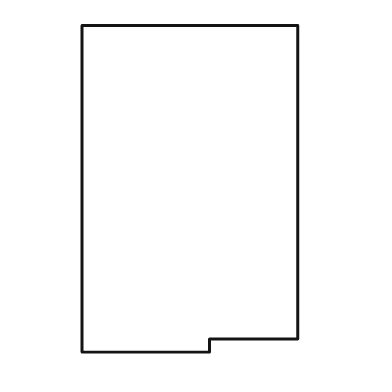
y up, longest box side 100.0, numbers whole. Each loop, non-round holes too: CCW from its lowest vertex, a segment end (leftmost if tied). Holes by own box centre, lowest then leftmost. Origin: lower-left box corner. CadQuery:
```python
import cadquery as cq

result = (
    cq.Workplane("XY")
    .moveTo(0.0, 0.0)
    .lineTo(39.0, 0.0)
    .lineTo(39.0, 4.0)
    .lineTo(66.0, 4.0)
    .lineTo(66.0, 100.0)
    .lineTo(0.0, 100.0)
    .close()
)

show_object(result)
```